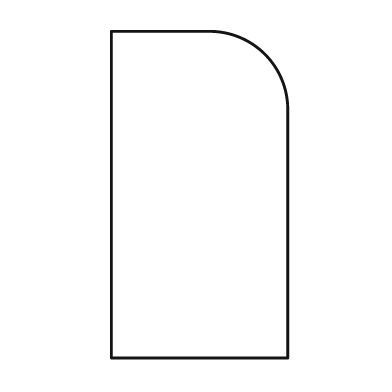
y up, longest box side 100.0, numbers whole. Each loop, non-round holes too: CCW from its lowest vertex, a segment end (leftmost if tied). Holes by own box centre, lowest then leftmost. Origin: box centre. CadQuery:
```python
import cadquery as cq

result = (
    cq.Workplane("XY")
    .moveTo(-27.0, -50.0)
    .lineTo(27.0, -50.0)
    .lineTo(27.0, 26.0)
    .threePointArc((20.0, 43.0), (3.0, 50.0))
    .lineTo(-27.0, 50.0)
    .close()
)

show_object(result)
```